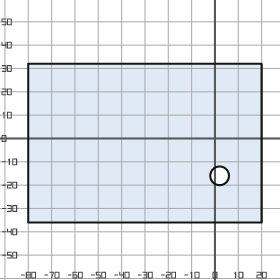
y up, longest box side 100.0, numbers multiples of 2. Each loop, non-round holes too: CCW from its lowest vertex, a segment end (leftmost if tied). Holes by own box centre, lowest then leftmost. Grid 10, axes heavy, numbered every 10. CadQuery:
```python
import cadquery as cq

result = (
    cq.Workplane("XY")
    .moveTo(-80.0, -36.0)
    .lineTo(20.0, -36.0)
    .lineTo(20.0, 32.0)
    .lineTo(-80.0, 32.0)
    .close()
    .moveTo(2.0, -16.0)
    .circle(4.0)
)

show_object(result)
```